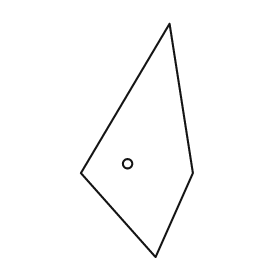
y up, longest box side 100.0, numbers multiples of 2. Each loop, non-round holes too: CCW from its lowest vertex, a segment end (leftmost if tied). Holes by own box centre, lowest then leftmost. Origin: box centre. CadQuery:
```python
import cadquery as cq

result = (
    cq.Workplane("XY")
    .moveTo(8.0, -50.0)
    .lineTo(24.0, -14.0)
    .lineTo(14.0, 50.0)
    .lineTo(-24.0, -14.0)
    .close()
    .moveTo(-4.0, -10.0)
    .circle(2.0)
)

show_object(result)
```